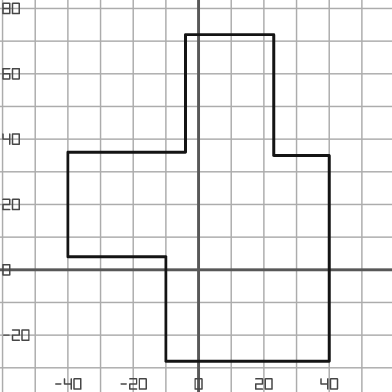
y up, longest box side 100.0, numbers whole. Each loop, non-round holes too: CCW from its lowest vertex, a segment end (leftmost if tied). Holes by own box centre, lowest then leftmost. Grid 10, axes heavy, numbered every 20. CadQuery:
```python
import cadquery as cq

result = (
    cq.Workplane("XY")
    .moveTo(-10.0, -28.0)
    .lineTo(40.0, -28.0)
    .lineTo(40.0, 35.0)
    .lineTo(23.0, 35.0)
    .lineTo(23.0, 72.0)
    .lineTo(-4.0, 72.0)
    .lineTo(-4.0, 36.0)
    .lineTo(-40.0, 36.0)
    .lineTo(-40.0, 4.0)
    .lineTo(-10.0, 4.0)
    .close()
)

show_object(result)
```